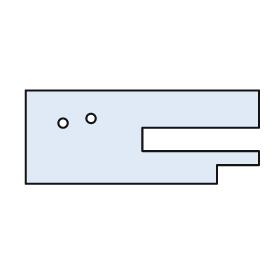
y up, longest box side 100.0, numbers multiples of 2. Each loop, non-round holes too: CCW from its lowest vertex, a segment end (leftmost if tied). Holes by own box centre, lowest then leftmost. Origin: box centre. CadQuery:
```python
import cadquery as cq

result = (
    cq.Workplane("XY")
    .moveTo(-50.0, -20.0)
    .lineTo(32.0, -20.0)
    .lineTo(32.0, -12.0)
    .lineTo(50.0, -12.0)
    .lineTo(50.0, -6.0)
    .lineTo(0.0, -6.0)
    .lineTo(0.0, 4.0)
    .lineTo(50.0, 4.0)
    .lineTo(50.0, 20.0)
    .lineTo(-50.0, 20.0)
    .close()
    .moveTo(-34.0, 6.0)
    .circle(2.0)
    .moveTo(-22.0, 8.0)
    .circle(2.0)
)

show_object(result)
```